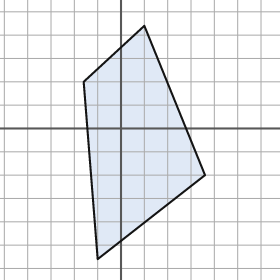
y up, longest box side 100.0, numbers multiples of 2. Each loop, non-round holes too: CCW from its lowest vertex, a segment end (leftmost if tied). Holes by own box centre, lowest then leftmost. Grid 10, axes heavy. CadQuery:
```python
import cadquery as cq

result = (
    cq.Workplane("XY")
    .moveTo(-10.0, -56.0)
    .lineTo(36.0, -20.0)
    .lineTo(10.0, 44.0)
    .lineTo(-16.0, 20.0)
    .close()
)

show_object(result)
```